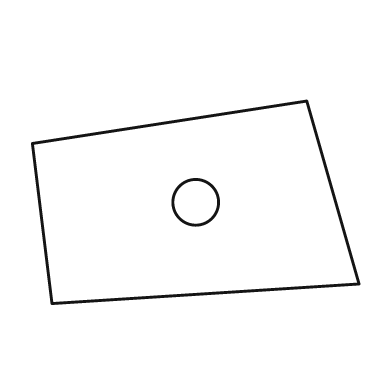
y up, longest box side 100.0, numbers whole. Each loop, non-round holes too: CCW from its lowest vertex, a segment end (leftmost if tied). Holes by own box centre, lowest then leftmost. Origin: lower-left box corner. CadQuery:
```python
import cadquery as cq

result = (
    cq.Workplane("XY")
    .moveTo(6.0, 0.0)
    .lineTo(100.0, 6.0)
    .lineTo(84.0, 62.0)
    .lineTo(0.0, 49.0)
    .close()
    .moveTo(50.0, 31.0)
    .circle(7.0)
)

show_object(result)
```